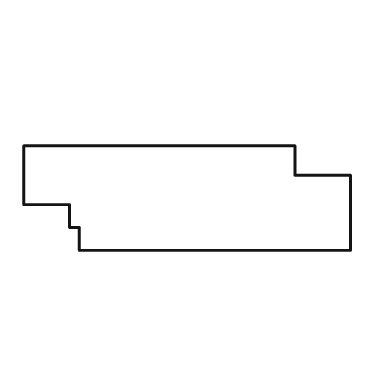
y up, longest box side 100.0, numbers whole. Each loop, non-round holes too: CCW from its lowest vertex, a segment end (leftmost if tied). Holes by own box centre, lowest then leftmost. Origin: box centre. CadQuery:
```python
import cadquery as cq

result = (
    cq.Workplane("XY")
    .moveTo(-33.0, -16.0)
    .lineTo(50.0, -16.0)
    .lineTo(50.0, 7.0)
    .lineTo(33.0, 7.0)
    .lineTo(33.0, 16.0)
    .lineTo(-50.0, 16.0)
    .lineTo(-50.0, -2.0)
    .lineTo(-36.0, -2.0)
    .lineTo(-36.0, -9.0)
    .lineTo(-33.0, -9.0)
    .close()
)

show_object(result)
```